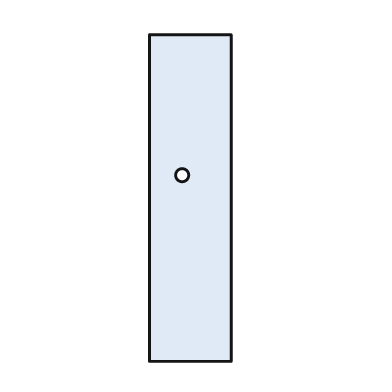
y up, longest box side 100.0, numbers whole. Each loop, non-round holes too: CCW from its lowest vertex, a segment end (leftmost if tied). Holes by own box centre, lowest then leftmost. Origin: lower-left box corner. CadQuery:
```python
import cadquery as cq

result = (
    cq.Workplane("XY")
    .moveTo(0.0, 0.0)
    .lineTo(25.0, 0.0)
    .lineTo(25.0, 100.0)
    .lineTo(0.0, 100.0)
    .close()
    .moveTo(10.0, 57.0)
    .circle(2.0)
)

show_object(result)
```